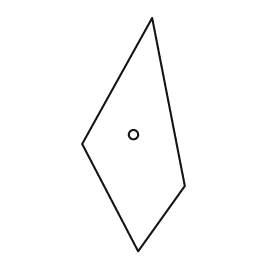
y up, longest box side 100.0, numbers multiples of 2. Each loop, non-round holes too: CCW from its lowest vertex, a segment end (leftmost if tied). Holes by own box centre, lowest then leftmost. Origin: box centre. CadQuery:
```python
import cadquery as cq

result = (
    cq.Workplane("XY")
    .moveTo(2.0, -50.0)
    .lineTo(22.0, -22.0)
    .lineTo(8.0, 50.0)
    .lineTo(-22.0, -4.0)
    .close()
    .moveTo(0.0, 0.0)
    .circle(2.0)
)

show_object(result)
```